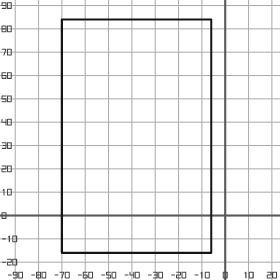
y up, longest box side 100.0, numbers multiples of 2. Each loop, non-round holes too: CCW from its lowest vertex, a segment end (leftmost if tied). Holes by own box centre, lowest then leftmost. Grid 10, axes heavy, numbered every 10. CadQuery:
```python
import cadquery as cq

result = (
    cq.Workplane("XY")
    .moveTo(-70.0, -16.0)
    .lineTo(-6.0, -16.0)
    .lineTo(-6.0, 84.0)
    .lineTo(-70.0, 84.0)
    .close()
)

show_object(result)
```